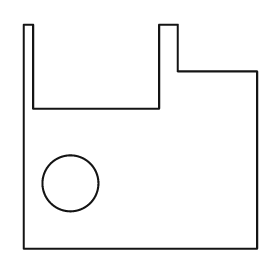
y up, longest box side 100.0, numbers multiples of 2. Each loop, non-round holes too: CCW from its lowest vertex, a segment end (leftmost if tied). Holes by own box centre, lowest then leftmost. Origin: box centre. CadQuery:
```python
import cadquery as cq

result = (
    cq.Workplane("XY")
    .moveTo(-50.0, -48.0)
    .lineTo(50.0, -48.0)
    .lineTo(50.0, 28.0)
    .lineTo(16.0, 28.0)
    .lineTo(16.0, 48.0)
    .lineTo(8.0, 48.0)
    .lineTo(8.0, 12.0)
    .lineTo(-46.0, 12.0)
    .lineTo(-46.0, 48.0)
    .lineTo(-50.0, 48.0)
    .close()
    .moveTo(-30.0, -20.0)
    .circle(12.0)
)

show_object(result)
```